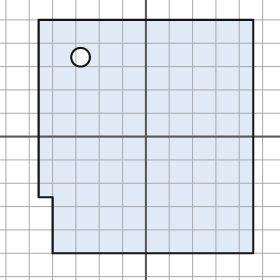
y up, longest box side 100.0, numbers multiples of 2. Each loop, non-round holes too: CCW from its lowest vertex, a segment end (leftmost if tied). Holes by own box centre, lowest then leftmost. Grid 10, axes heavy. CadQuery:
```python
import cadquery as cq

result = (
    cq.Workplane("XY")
    .moveTo(-40.0, -50.0)
    .lineTo(46.0, -50.0)
    .lineTo(46.0, 50.0)
    .lineTo(-46.0, 50.0)
    .lineTo(-46.0, -26.0)
    .lineTo(-40.0, -26.0)
    .close()
    .moveTo(-28.0, 34.0)
    .circle(4.0)
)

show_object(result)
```